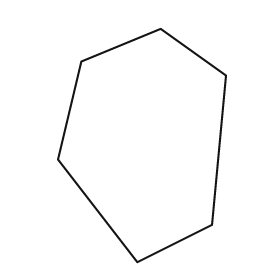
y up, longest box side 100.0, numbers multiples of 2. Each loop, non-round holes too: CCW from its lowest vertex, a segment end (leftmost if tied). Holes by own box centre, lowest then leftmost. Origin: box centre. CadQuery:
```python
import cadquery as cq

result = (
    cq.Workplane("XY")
    .moveTo(-2.0, -50.0)
    .lineTo(30.0, -34.0)
    .lineTo(36.0, 30.0)
    .lineTo(8.0, 50.0)
    .lineTo(-26.0, 36.0)
    .lineTo(-36.0, -6.0)
    .close()
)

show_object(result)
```